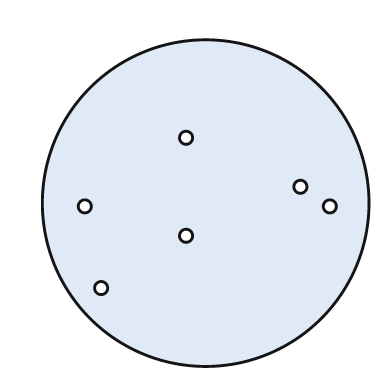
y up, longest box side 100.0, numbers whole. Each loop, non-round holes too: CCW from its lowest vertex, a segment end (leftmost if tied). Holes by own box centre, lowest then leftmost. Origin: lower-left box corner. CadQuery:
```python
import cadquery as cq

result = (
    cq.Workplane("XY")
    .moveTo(50.0, 50.0)
    .circle(50.0)
    .moveTo(18.0, 24.0)
    .circle(2.0)
    .moveTo(44.0, 40.0)
    .circle(2.0)
    .moveTo(13.0, 49.0)
    .circle(2.0)
    .moveTo(88.0, 49.0)
    .circle(2.0)
    .moveTo(79.0, 55.0)
    .circle(2.0)
    .moveTo(44.0, 70.0)
    .circle(2.0)
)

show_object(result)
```